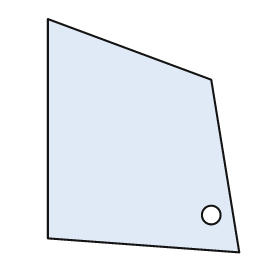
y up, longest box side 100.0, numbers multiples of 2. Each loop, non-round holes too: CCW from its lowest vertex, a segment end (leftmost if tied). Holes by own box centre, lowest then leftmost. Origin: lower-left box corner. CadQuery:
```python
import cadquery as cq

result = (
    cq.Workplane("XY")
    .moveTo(82.0, 0.0)
    .lineTo(70.0, 74.0)
    .lineTo(0.0, 100.0)
    .lineTo(0.0, 6.0)
    .close()
    .moveTo(70.0, 16.0)
    .circle(4.0)
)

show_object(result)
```